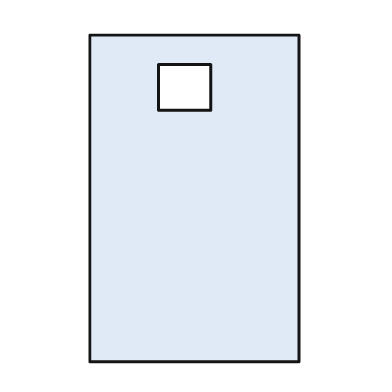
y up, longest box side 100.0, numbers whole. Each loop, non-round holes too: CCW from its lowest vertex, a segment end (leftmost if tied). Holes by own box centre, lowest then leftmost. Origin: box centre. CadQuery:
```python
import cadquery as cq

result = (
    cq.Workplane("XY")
    .moveTo(-32.0, -50.0)
    .lineTo(32.0, -50.0)
    .lineTo(32.0, 50.0)
    .lineTo(-32.0, 50.0)
    .close()
    .moveTo(-11.0, 27.0)
    .lineTo(5.0, 27.0)
    .lineTo(5.0, 41.0)
    .lineTo(-11.0, 41.0)
    .close()
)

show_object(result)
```